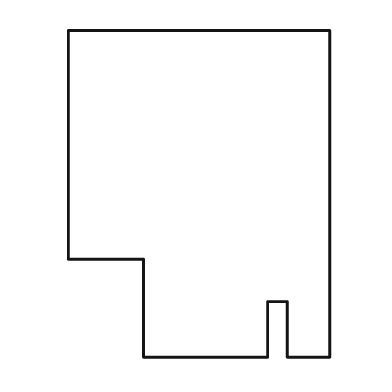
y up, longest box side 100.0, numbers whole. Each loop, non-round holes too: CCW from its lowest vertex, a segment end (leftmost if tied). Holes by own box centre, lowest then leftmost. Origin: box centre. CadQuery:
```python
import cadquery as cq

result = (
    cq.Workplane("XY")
    .moveTo(-17.0, -50.0)
    .lineTo(21.0, -50.0)
    .lineTo(21.0, -33.0)
    .lineTo(27.0, -33.0)
    .lineTo(27.0, -50.0)
    .lineTo(40.0, -50.0)
    .lineTo(40.0, 50.0)
    .lineTo(-40.0, 50.0)
    .lineTo(-40.0, -20.0)
    .lineTo(-17.0, -20.0)
    .close()
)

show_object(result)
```